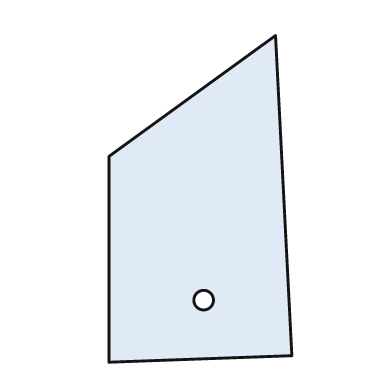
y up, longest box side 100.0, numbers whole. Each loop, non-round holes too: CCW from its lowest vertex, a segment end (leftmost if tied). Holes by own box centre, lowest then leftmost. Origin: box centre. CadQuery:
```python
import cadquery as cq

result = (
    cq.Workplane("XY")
    .moveTo(-28.0, -50.0)
    .lineTo(28.0, -48.0)
    .lineTo(23.0, 50.0)
    .lineTo(-28.0, 13.0)
    .close()
    .moveTo(1.0, -31.0)
    .circle(3.0)
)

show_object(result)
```